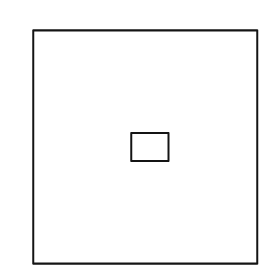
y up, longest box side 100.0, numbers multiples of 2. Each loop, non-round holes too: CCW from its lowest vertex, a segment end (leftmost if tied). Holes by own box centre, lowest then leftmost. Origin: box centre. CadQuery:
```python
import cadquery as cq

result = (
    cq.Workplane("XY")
    .moveTo(-48.0, -50.0)
    .lineTo(48.0, -50.0)
    .lineTo(48.0, 50.0)
    .lineTo(-48.0, 50.0)
    .close()
    .moveTo(-6.0, -6.0)
    .lineTo(10.0, -6.0)
    .lineTo(10.0, 6.0)
    .lineTo(-6.0, 6.0)
    .close()
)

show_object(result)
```